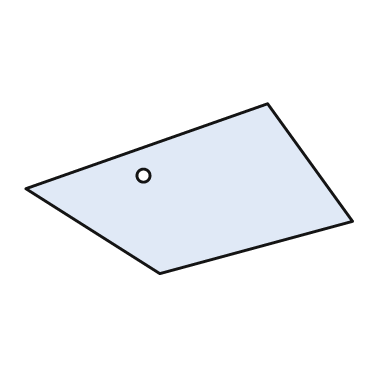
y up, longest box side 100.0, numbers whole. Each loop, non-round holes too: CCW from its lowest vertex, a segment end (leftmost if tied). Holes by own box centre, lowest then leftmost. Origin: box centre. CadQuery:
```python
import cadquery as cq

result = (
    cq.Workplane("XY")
    .moveTo(-9.0, -26.0)
    .lineTo(50.0, -10.0)
    .lineTo(24.0, 26.0)
    .lineTo(-50.0, 0.0)
    .close()
    .moveTo(-14.0, 4.0)
    .circle(2.0)
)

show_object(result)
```